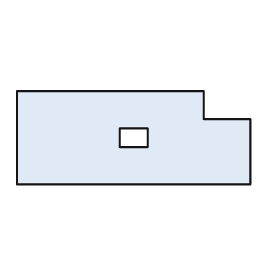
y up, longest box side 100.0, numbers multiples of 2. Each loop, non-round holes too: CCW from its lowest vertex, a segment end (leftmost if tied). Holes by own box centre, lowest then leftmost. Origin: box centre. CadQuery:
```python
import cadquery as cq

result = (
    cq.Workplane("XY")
    .moveTo(-50.0, -20.0)
    .lineTo(50.0, -20.0)
    .lineTo(50.0, 8.0)
    .lineTo(30.0, 8.0)
    .lineTo(30.0, 20.0)
    .lineTo(-50.0, 20.0)
    .close()
    .moveTo(-6.0, -4.0)
    .lineTo(6.0, -4.0)
    .lineTo(6.0, 4.0)
    .lineTo(-6.0, 4.0)
    .close()
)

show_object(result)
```